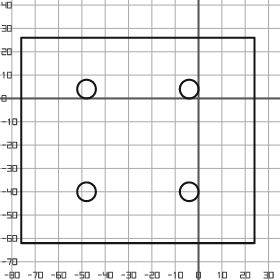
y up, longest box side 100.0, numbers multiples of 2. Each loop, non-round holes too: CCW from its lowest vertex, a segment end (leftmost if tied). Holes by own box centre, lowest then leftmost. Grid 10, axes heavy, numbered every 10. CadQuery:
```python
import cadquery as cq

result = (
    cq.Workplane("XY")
    .moveTo(-76.0, -62.0)
    .lineTo(24.0, -62.0)
    .lineTo(24.0, 26.0)
    .lineTo(-76.0, 26.0)
    .close()
    .moveTo(-48.0, -40.0)
    .circle(4.0)
    .moveTo(-4.0, -40.0)
    .circle(4.0)
    .moveTo(-48.0, 4.0)
    .circle(4.0)
    .moveTo(-4.0, 4.0)
    .circle(4.0)
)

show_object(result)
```